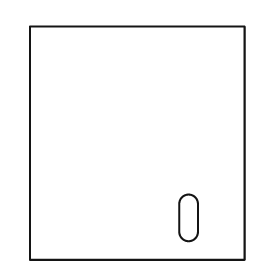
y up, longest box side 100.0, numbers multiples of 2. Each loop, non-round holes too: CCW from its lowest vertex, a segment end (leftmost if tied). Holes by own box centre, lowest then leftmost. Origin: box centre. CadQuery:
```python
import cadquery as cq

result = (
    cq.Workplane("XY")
    .moveTo(-46.0, -50.0)
    .lineTo(46.0, -50.0)
    .lineTo(46.0, 50.0)
    .lineTo(-46.0, 50.0)
    .close()
    .moveTo(18.0, -38.0)
    .threePointArc((22.0, -42.0), (26.0, -38.0))
    .lineTo(26.0, -26.0)
    .threePointArc((22.0, -22.0), (18.0, -26.0))
    .close()
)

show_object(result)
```